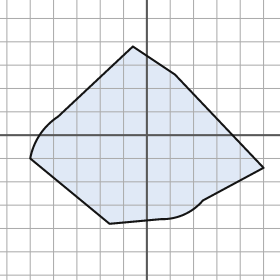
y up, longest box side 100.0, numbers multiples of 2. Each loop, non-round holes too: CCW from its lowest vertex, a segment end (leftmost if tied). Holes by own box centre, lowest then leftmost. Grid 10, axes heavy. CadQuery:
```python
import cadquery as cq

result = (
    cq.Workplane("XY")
    .moveTo(-16.0, -38.0)
    .lineTo(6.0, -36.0)
    .threePointArc((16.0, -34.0), (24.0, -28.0))
    .lineTo(50.0, -14.0)
    .lineTo(12.0, 26.0)
    .lineTo(-6.0, 38.0)
    .lineTo(-38.0, 8.0)
    .threePointArc((-46.0, 0.0), (-50.0, -10.0))
    .close()
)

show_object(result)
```